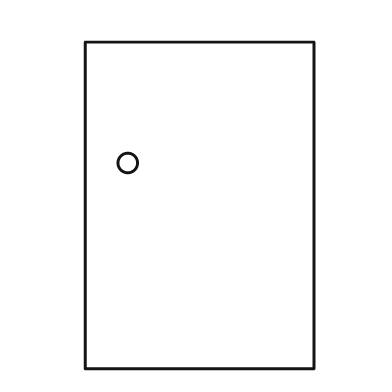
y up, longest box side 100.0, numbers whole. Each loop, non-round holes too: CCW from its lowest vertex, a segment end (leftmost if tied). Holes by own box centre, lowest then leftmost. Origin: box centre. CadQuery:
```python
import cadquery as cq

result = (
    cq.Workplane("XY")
    .moveTo(-35.0, -50.0)
    .lineTo(35.0, -50.0)
    .lineTo(35.0, 50.0)
    .lineTo(-35.0, 50.0)
    .close()
    .moveTo(-22.0, 13.0)
    .circle(3.0)
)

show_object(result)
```